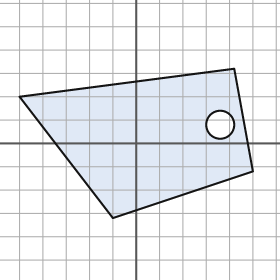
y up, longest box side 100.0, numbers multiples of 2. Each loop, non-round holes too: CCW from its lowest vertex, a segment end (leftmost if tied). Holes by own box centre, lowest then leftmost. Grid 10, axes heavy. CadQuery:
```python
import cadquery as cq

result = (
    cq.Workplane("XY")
    .moveTo(-10.0, -32.0)
    .lineTo(50.0, -12.0)
    .lineTo(42.0, 32.0)
    .lineTo(-50.0, 20.0)
    .close()
    .moveTo(36.0, 8.0)
    .circle(6.0)
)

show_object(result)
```